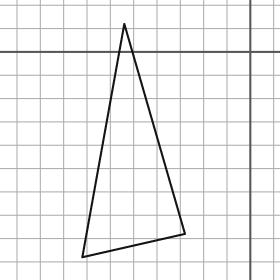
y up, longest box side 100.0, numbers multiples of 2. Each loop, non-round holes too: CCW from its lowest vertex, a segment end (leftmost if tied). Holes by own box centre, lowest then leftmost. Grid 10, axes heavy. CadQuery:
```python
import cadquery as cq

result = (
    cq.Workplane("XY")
    .moveTo(-72.0, -88.0)
    .lineTo(-28.0, -78.0)
    .lineTo(-54.0, 12.0)
    .close()
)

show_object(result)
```